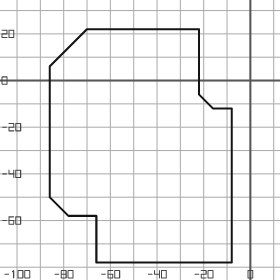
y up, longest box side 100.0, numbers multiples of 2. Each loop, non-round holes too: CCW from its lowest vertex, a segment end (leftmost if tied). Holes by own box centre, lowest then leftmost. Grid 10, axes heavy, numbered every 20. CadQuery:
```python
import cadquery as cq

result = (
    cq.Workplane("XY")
    .moveTo(-66.0, -78.0)
    .lineTo(-8.0, -78.0)
    .lineTo(-8.0, -12.0)
    .lineTo(-16.0, -12.0)
    .lineTo(-22.0, -6.0)
    .lineTo(-22.0, 22.0)
    .lineTo(-70.0, 22.0)
    .lineTo(-86.0, 6.0)
    .lineTo(-86.0, -50.0)
    .lineTo(-78.0, -58.0)
    .lineTo(-66.0, -58.0)
    .close()
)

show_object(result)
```